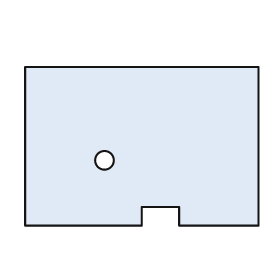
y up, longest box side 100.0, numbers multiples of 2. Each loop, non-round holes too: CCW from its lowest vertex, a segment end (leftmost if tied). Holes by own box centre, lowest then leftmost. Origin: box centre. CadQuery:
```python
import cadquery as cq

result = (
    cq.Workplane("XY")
    .moveTo(-50.0, -34.0)
    .lineTo(0.0, -34.0)
    .lineTo(0.0, -26.0)
    .lineTo(16.0, -26.0)
    .lineTo(16.0, -34.0)
    .lineTo(50.0, -34.0)
    .lineTo(50.0, 34.0)
    .lineTo(-50.0, 34.0)
    .close()
    .moveTo(-16.0, -6.0)
    .circle(4.0)
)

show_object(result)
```